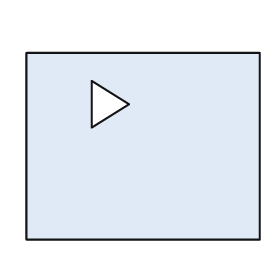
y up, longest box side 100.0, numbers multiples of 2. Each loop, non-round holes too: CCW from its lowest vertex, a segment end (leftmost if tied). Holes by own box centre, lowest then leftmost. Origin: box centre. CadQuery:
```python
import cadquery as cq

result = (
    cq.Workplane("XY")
    .moveTo(-50.0, -40.0)
    .lineTo(50.0, -40.0)
    .lineTo(50.0, 40.0)
    .lineTo(-50.0, 40.0)
    .close()
    .moveTo(-22.0, 8.0)
    .lineTo(-6.0, 18.0)
    .lineTo(-22.0, 28.0)
    .close()
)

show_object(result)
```